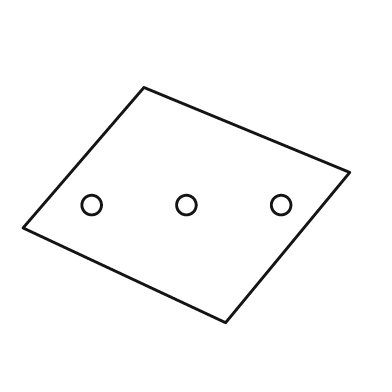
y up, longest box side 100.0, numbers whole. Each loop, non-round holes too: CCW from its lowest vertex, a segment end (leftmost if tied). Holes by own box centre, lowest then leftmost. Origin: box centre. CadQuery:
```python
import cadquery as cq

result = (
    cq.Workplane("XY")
    .moveTo(12.0, -36.0)
    .lineTo(50.0, 10.0)
    .lineTo(-13.0, 36.0)
    .lineTo(-50.0, -7.0)
    .close()
    .moveTo(-29.0, 0.0)
    .circle(3.0)
    .moveTo(0.0, 0.0)
    .circle(3.0)
    .moveTo(29.0, 0.0)
    .circle(3.0)
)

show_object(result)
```